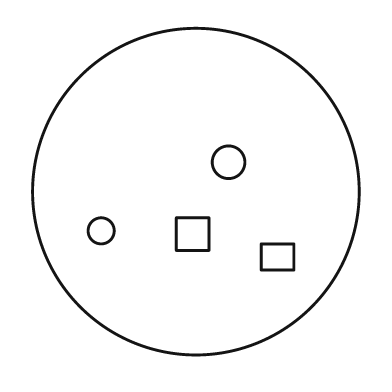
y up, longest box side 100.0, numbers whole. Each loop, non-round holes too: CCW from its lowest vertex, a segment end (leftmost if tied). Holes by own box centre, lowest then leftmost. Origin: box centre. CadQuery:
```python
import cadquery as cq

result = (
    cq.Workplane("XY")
    .moveTo(0.0, 0.0)
    .circle(50.0)
    .moveTo(20.0, -24.0)
    .lineTo(30.0, -24.0)
    .lineTo(30.0, -16.0)
    .lineTo(20.0, -16.0)
    .close()
    .moveTo(-6.0, -18.0)
    .lineTo(4.0, -18.0)
    .lineTo(4.0, -8.0)
    .lineTo(-6.0, -8.0)
    .close()
    .moveTo(-29.0, -12.0)
    .circle(4.0)
    .moveTo(10.0, 9.0)
    .circle(5.0)
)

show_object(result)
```